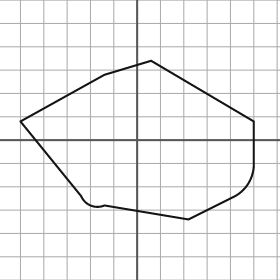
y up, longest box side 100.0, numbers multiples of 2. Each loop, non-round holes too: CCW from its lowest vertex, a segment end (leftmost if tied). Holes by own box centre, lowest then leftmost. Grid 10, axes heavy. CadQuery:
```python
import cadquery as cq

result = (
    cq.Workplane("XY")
    .moveTo(22.0, -34.0)
    .lineTo(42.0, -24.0)
    .threePointArc((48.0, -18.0), (50.0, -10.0))
    .lineTo(50.0, 8.0)
    .lineTo(6.0, 34.0)
    .lineTo(-14.0, 28.0)
    .lineTo(-50.0, 8.0)
    .lineTo(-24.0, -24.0)
    .threePointArc((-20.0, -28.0), (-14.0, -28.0))
    .close()
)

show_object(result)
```